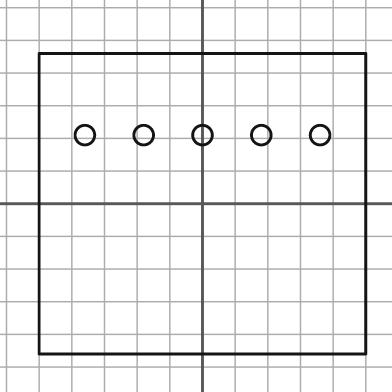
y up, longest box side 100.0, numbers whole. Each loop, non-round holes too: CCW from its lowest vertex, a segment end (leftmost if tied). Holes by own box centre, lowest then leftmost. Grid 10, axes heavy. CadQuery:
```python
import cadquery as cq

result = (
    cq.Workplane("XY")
    .moveTo(-50.0, -46.0)
    .lineTo(50.0, -46.0)
    .lineTo(50.0, 46.0)
    .lineTo(-50.0, 46.0)
    .close()
    .moveTo(-36.0, 21.0)
    .circle(3.0)
    .moveTo(-18.0, 21.0)
    .circle(3.0)
    .moveTo(0.0, 21.0)
    .circle(3.0)
    .moveTo(18.0, 21.0)
    .circle(3.0)
    .moveTo(36.0, 21.0)
    .circle(3.0)
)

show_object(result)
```